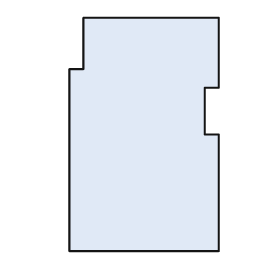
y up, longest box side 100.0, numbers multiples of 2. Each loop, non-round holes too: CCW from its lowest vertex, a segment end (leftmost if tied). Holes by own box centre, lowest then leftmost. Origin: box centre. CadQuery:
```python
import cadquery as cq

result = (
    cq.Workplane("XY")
    .moveTo(-32.0, -50.0)
    .lineTo(32.0, -50.0)
    .lineTo(32.0, 0.0)
    .lineTo(26.0, 0.0)
    .lineTo(26.0, 20.0)
    .lineTo(32.0, 20.0)
    .lineTo(32.0, 50.0)
    .lineTo(-26.0, 50.0)
    .lineTo(-26.0, 28.0)
    .lineTo(-32.0, 28.0)
    .close()
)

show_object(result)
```